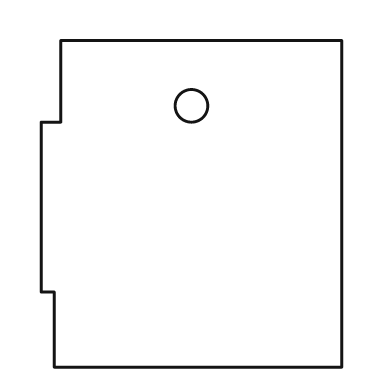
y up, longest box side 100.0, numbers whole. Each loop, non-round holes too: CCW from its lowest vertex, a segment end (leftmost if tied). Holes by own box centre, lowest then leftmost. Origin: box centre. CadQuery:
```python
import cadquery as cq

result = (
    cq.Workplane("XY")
    .moveTo(-42.0, -50.0)
    .lineTo(46.0, -50.0)
    .lineTo(46.0, 50.0)
    .lineTo(-40.0, 50.0)
    .lineTo(-40.0, 25.0)
    .lineTo(-46.0, 25.0)
    .lineTo(-46.0, -27.0)
    .lineTo(-42.0, -27.0)
    .close()
    .moveTo(0.0, 30.0)
    .circle(5.0)
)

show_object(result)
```